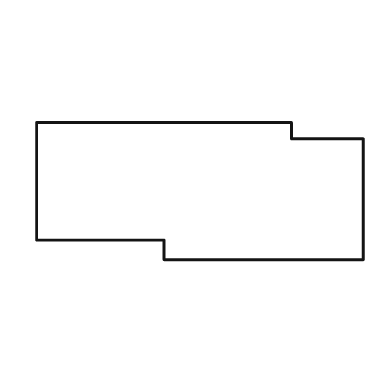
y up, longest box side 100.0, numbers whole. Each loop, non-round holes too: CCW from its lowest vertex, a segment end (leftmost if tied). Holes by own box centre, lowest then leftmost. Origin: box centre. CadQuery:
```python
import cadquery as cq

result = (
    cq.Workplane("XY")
    .moveTo(-11.0, -21.0)
    .lineTo(50.0, -21.0)
    .lineTo(50.0, 16.0)
    .lineTo(28.0, 16.0)
    .lineTo(28.0, 21.0)
    .lineTo(-50.0, 21.0)
    .lineTo(-50.0, -15.0)
    .lineTo(-11.0, -15.0)
    .close()
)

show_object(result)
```